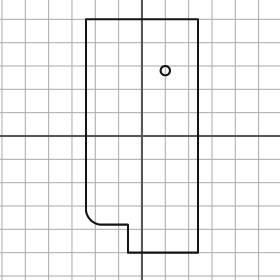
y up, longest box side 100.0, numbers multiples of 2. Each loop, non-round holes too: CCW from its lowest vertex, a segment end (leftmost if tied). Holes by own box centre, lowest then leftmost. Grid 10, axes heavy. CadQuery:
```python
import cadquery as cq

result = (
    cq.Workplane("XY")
    .moveTo(-6.0, -50.0)
    .lineTo(24.0, -50.0)
    .lineTo(24.0, 50.0)
    .lineTo(-24.0, 50.0)
    .lineTo(-24.0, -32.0)
    .threePointArc((-22.0, -36.0), (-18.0, -38.0))
    .lineTo(-6.0, -38.0)
    .close()
    .moveTo(10.0, 28.0)
    .circle(2.0)
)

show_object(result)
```